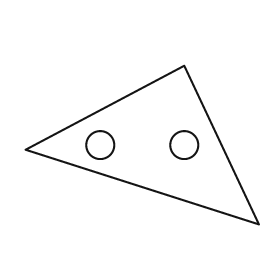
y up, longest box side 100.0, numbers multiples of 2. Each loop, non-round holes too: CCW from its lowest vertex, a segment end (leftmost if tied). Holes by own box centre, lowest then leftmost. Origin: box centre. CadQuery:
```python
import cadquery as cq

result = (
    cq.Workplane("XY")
    .moveTo(50.0, -34.0)
    .lineTo(18.0, 34.0)
    .lineTo(-50.0, -2.0)
    .close()
    .moveTo(-18.0, 0.0)
    .circle(6.0)
    .moveTo(18.0, 0.0)
    .circle(6.0)
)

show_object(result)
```